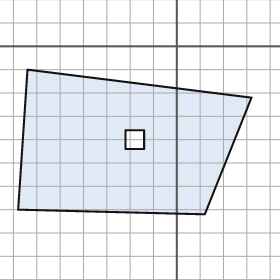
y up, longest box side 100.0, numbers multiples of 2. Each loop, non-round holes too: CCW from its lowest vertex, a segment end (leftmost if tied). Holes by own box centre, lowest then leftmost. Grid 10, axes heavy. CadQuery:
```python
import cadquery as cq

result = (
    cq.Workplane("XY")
    .moveTo(12.0, -72.0)
    .lineTo(32.0, -22.0)
    .lineTo(-64.0, -10.0)
    .lineTo(-68.0, -70.0)
    .close()
    .moveTo(-22.0, -44.0)
    .lineTo(-14.0, -44.0)
    .lineTo(-14.0, -36.0)
    .lineTo(-22.0, -36.0)
    .close()
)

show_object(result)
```